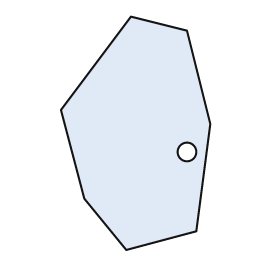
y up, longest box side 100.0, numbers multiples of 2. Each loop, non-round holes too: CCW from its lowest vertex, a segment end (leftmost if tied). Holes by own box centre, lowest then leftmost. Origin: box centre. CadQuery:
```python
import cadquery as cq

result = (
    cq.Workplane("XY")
    .moveTo(-4.0, -50.0)
    .lineTo(26.0, -42.0)
    .lineTo(32.0, 4.0)
    .lineTo(22.0, 44.0)
    .lineTo(-2.0, 50.0)
    .lineTo(-32.0, 10.0)
    .lineTo(-22.0, -28.0)
    .close()
    .moveTo(22.0, -8.0)
    .circle(4.0)
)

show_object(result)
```